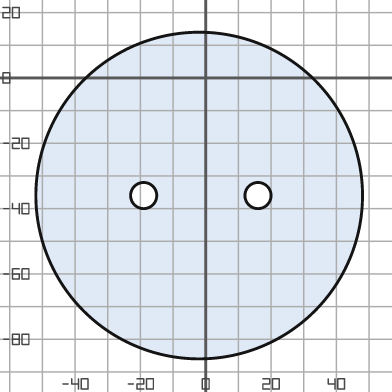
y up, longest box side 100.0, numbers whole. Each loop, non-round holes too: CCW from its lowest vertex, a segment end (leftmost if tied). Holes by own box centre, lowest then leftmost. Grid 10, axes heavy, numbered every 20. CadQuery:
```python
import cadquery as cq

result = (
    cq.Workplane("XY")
    .moveTo(-2.0, -36.0)
    .circle(50.0)
    .moveTo(-19.0, -36.0)
    .circle(4.0)
    .moveTo(16.0, -36.0)
    .circle(4.0)
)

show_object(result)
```